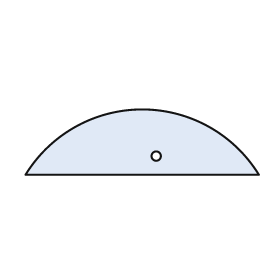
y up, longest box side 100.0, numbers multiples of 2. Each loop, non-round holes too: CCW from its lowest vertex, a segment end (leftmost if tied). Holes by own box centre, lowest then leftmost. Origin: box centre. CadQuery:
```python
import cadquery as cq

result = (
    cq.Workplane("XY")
    .moveTo(-50.0, -14.0)
    .lineTo(50.0, -14.0)
    .threePointArc((0.0, 14.0), (-50.0, -14.0))
    .close()
    .moveTo(6.0, -6.0)
    .circle(2.0)
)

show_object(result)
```